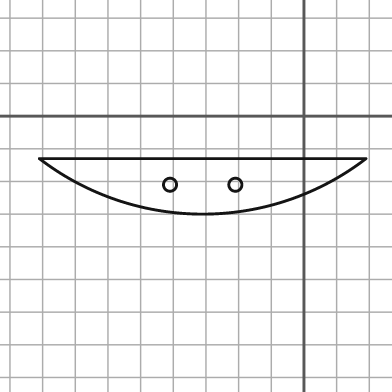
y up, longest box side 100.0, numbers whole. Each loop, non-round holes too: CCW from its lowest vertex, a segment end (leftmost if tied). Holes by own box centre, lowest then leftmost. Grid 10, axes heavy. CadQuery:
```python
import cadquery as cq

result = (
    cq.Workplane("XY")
    .moveTo(-81.0, -13.0)
    .threePointArc((-31.0, -30.0), (19.0, -13.0))
    .close()
    .moveTo(-41.0, -21.0)
    .circle(2.0)
    .moveTo(-21.0, -21.0)
    .circle(2.0)
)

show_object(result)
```